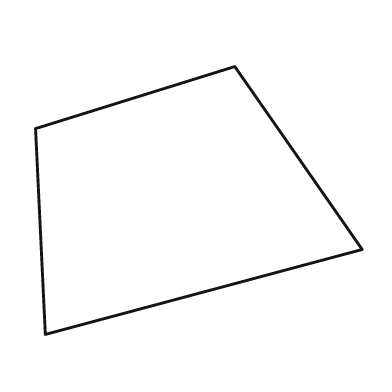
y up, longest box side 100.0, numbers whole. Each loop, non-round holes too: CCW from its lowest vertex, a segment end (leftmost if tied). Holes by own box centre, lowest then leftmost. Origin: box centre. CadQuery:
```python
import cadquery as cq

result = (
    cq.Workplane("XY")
    .moveTo(-47.0, -41.0)
    .lineTo(50.0, -15.0)
    .lineTo(11.0, 41.0)
    .lineTo(-50.0, 22.0)
    .close()
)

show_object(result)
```